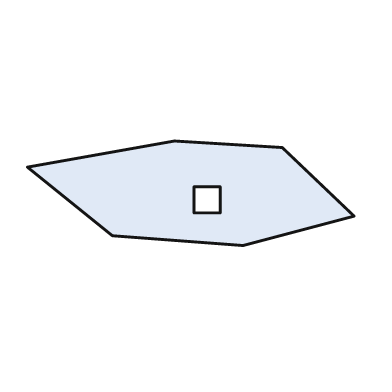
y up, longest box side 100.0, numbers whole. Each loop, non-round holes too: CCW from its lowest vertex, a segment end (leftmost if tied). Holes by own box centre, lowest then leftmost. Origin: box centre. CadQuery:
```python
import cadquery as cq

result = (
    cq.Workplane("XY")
    .moveTo(16.0, -16.0)
    .lineTo(50.0, -7.0)
    .lineTo(28.0, 14.0)
    .lineTo(-5.0, 16.0)
    .lineTo(-50.0, 8.0)
    .lineTo(-24.0, -13.0)
    .close()
    .moveTo(1.0, -6.0)
    .lineTo(9.0, -6.0)
    .lineTo(9.0, 2.0)
    .lineTo(1.0, 2.0)
    .close()
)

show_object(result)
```